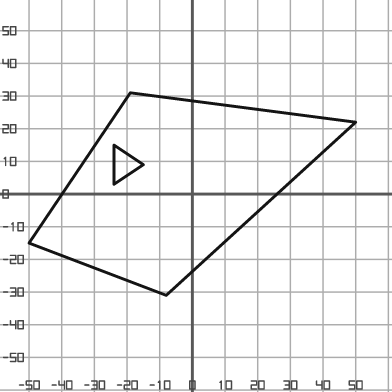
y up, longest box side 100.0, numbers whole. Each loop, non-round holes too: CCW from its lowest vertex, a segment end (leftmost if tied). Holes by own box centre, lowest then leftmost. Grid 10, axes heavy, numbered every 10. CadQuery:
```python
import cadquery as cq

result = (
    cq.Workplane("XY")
    .moveTo(-8.0, -31.0)
    .lineTo(50.0, 22.0)
    .lineTo(-19.0, 31.0)
    .lineTo(-50.0, -15.0)
    .close()
    .moveTo(-24.0, 3.0)
    .lineTo(-15.0, 9.0)
    .lineTo(-24.0, 15.0)
    .close()
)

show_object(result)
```